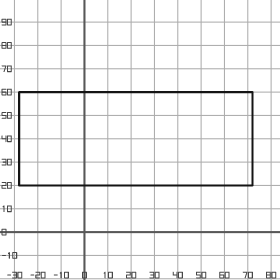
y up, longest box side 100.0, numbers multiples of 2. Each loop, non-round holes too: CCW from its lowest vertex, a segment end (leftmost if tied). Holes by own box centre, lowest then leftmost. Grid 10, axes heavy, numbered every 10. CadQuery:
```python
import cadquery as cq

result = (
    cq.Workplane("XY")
    .moveTo(-28.0, 20.0)
    .lineTo(72.0, 20.0)
    .lineTo(72.0, 60.0)
    .lineTo(-28.0, 60.0)
    .close()
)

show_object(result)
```